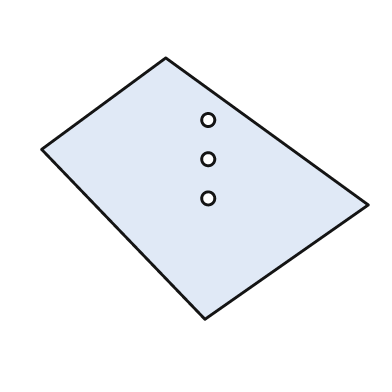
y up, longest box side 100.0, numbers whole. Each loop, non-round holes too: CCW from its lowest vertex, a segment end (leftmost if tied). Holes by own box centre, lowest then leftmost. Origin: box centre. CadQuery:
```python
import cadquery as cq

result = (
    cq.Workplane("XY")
    .moveTo(0.0, -40.0)
    .lineTo(50.0, -5.0)
    .lineTo(-12.0, 40.0)
    .lineTo(-50.0, 12.0)
    .close()
    .moveTo(1.0, -3.0)
    .circle(2.0)
    .moveTo(1.0, 9.0)
    .circle(2.0)
    .moveTo(1.0, 21.0)
    .circle(2.0)
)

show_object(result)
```